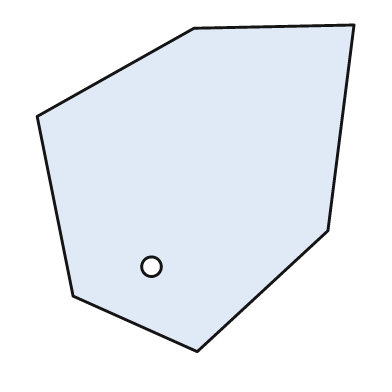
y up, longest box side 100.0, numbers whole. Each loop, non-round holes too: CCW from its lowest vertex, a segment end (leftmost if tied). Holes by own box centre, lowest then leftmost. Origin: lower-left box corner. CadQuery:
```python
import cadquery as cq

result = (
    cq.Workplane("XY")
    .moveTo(49.0, 0.0)
    .lineTo(89.0, 37.0)
    .lineTo(97.0, 100.0)
    .lineTo(48.0, 99.0)
    .lineTo(0.0, 72.0)
    .lineTo(11.0, 17.0)
    .close()
    .moveTo(35.0, 26.0)
    .circle(3.0)
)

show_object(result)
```